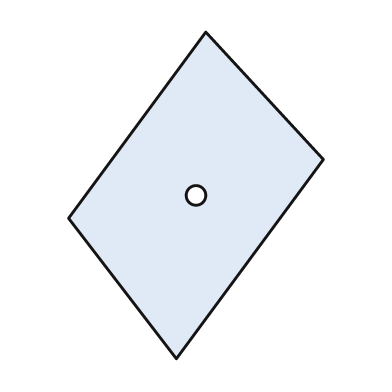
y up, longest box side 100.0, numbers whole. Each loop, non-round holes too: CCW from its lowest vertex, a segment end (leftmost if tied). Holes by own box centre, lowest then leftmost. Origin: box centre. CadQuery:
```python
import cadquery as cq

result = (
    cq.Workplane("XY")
    .moveTo(-6.0, -50.0)
    .lineTo(39.0, 11.0)
    .lineTo(3.0, 50.0)
    .lineTo(-39.0, -7.0)
    .close()
    .moveTo(0.0, 0.0)
    .circle(3.0)
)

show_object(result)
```